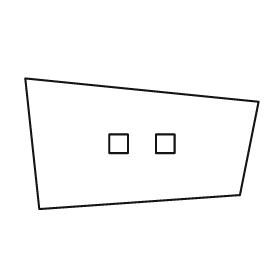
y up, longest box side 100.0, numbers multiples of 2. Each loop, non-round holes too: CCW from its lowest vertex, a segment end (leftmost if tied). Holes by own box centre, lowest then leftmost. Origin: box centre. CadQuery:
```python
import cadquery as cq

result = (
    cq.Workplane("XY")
    .moveTo(-44.0, -28.0)
    .lineTo(42.0, -22.0)
    .lineTo(50.0, 18.0)
    .lineTo(-50.0, 28.0)
    .close()
    .moveTo(-14.0, -4.0)
    .lineTo(-6.0, -4.0)
    .lineTo(-6.0, 4.0)
    .lineTo(-14.0, 4.0)
    .close()
    .moveTo(6.0, -4.0)
    .lineTo(14.0, -4.0)
    .lineTo(14.0, 4.0)
    .lineTo(6.0, 4.0)
    .close()
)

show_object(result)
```